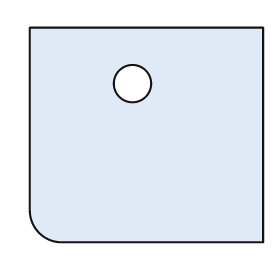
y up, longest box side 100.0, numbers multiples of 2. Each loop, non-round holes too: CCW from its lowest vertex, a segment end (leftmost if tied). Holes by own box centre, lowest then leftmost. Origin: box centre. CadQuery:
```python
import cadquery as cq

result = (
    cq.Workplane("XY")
    .moveTo(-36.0, -46.0)
    .lineTo(50.0, -46.0)
    .lineTo(50.0, 46.0)
    .lineTo(-50.0, 46.0)
    .lineTo(-50.0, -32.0)
    .threePointArc((-46.0, -42.0), (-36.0, -46.0))
    .close()
    .moveTo(-6.0, 22.0)
    .circle(8.0)
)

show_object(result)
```